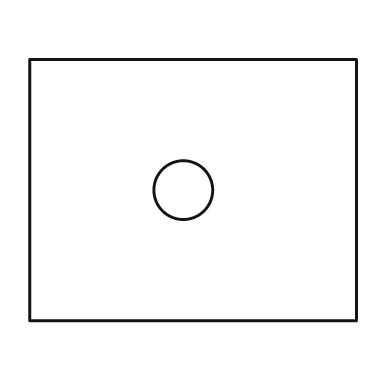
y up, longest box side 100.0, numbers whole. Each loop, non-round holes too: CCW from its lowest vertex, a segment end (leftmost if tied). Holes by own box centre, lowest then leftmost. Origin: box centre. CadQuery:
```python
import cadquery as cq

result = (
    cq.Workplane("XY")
    .moveTo(-50.0, -40.0)
    .lineTo(50.0, -40.0)
    .lineTo(50.0, 40.0)
    .lineTo(-50.0, 40.0)
    .close()
    .moveTo(-3.0, 0.0)
    .circle(9.0)
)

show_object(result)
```